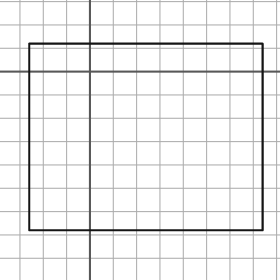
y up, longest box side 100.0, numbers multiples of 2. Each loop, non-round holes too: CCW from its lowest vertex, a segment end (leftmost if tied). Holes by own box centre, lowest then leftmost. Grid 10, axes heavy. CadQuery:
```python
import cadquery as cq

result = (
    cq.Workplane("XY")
    .moveTo(-26.0, -68.0)
    .lineTo(74.0, -68.0)
    .lineTo(74.0, 12.0)
    .lineTo(-26.0, 12.0)
    .close()
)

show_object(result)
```